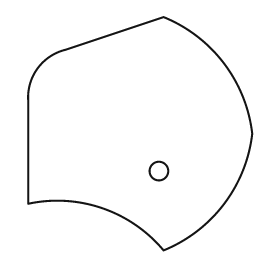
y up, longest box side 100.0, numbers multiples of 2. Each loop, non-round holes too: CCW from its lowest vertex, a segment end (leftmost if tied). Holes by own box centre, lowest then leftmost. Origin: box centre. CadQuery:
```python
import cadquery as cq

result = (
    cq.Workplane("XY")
    .moveTo(10.0, -50.0)
    .threePointArc((36.0, -30.0), (48.0, 0.0))
    .threePointArc((36.0, 30.0), (10.0, 50.0))
    .lineTo(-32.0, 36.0)
    .threePointArc((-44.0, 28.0), (-48.0, 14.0))
    .lineTo(-48.0, -30.0)
    .threePointArc((-16.0, -32.0), (10.0, -50.0))
    .close()
    .moveTo(8.0, -16.0)
    .circle(4.0)
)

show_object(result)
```